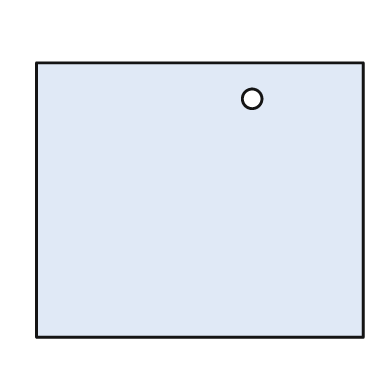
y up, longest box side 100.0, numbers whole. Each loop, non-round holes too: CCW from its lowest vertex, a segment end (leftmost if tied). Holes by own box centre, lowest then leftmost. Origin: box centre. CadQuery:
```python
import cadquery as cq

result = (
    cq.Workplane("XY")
    .moveTo(-50.0, -42.0)
    .lineTo(50.0, -42.0)
    .lineTo(50.0, 42.0)
    .lineTo(-50.0, 42.0)
    .close()
    .moveTo(16.0, 31.0)
    .circle(3.0)
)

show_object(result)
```